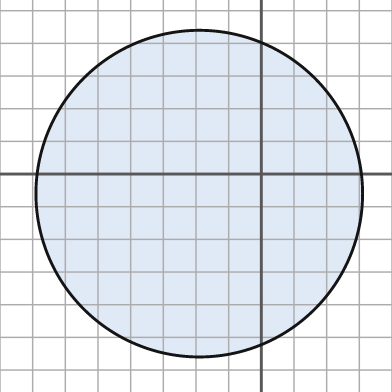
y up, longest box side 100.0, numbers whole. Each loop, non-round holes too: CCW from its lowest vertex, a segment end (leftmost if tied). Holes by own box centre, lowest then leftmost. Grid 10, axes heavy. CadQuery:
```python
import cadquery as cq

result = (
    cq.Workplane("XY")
    .moveTo(-19.0, -6.0)
    .circle(50.0)
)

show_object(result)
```